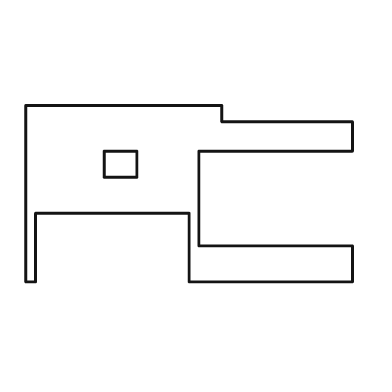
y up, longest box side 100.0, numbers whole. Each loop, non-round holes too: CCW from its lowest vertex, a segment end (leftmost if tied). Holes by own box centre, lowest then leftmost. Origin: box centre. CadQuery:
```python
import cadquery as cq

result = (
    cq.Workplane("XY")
    .moveTo(-50.0, -27.0)
    .lineTo(-47.0, -27.0)
    .lineTo(-47.0, -6.0)
    .lineTo(0.0, -6.0)
    .lineTo(0.0, -27.0)
    .lineTo(50.0, -27.0)
    .lineTo(50.0, -16.0)
    .lineTo(3.0, -16.0)
    .lineTo(3.0, 13.0)
    .lineTo(50.0, 13.0)
    .lineTo(50.0, 22.0)
    .lineTo(10.0, 22.0)
    .lineTo(10.0, 27.0)
    .lineTo(-50.0, 27.0)
    .close()
    .moveTo(-26.0, 5.0)
    .lineTo(-16.0, 5.0)
    .lineTo(-16.0, 13.0)
    .lineTo(-26.0, 13.0)
    .close()
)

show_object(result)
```